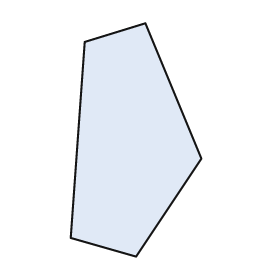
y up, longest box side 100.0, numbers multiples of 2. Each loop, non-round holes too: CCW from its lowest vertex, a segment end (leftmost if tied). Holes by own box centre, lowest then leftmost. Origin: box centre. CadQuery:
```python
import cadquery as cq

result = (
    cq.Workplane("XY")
    .moveTo(0.0, -50.0)
    .lineTo(28.0, -8.0)
    .lineTo(4.0, 50.0)
    .lineTo(-22.0, 42.0)
    .lineTo(-28.0, -42.0)
    .close()
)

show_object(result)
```